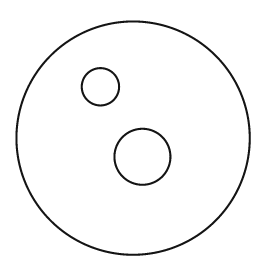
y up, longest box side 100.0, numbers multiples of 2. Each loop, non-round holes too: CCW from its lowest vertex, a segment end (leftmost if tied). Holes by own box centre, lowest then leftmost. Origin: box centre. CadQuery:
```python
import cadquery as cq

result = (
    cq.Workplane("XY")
    .moveTo(0.0, 0.0)
    .circle(50.0)
    .moveTo(4.0, -8.0)
    .circle(12.0)
    .moveTo(-14.0, 22.0)
    .circle(8.0)
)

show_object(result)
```